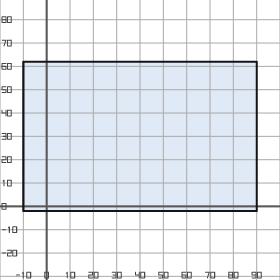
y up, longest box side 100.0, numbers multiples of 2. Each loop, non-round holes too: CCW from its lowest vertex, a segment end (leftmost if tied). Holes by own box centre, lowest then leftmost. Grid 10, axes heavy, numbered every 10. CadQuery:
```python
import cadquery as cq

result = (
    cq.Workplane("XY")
    .moveTo(-10.0, -2.0)
    .lineTo(90.0, -2.0)
    .lineTo(90.0, 62.0)
    .lineTo(-10.0, 62.0)
    .close()
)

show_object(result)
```